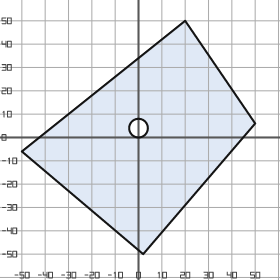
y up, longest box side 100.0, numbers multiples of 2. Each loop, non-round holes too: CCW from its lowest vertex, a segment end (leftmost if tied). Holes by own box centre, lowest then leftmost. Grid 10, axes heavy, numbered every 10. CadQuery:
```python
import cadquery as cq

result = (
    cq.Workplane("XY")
    .moveTo(2.0, -50.0)
    .lineTo(50.0, 6.0)
    .lineTo(20.0, 50.0)
    .lineTo(-50.0, -6.0)
    .close()
    .moveTo(0.0, 4.0)
    .circle(4.0)
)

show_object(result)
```